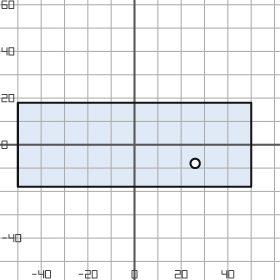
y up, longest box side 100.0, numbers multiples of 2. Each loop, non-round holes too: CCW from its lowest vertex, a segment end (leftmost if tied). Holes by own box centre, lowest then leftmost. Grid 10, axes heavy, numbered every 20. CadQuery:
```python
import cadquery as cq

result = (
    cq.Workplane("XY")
    .moveTo(-50.0, -18.0)
    .lineTo(50.0, -18.0)
    .lineTo(50.0, 18.0)
    .lineTo(-50.0, 18.0)
    .close()
    .moveTo(26.0, -8.0)
    .circle(2.0)
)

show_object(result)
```